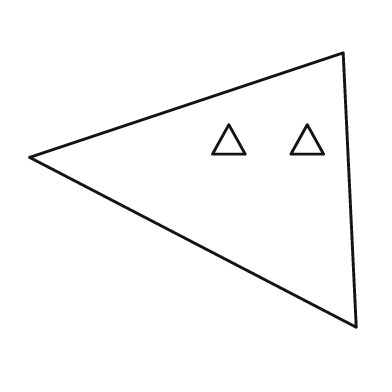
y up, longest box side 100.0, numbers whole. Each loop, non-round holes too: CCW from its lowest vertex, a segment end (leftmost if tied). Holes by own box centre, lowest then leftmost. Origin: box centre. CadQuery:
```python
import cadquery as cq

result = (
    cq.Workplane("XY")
    .moveTo(50.0, -42.0)
    .lineTo(46.0, 42.0)
    .lineTo(-50.0, 10.0)
    .close()
    .moveTo(6.0, 11.0)
    .lineTo(16.0, 11.0)
    .lineTo(11.0, 20.0)
    .close()
    .moveTo(30.0, 11.0)
    .lineTo(40.0, 11.0)
    .lineTo(35.0, 20.0)
    .close()
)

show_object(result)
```